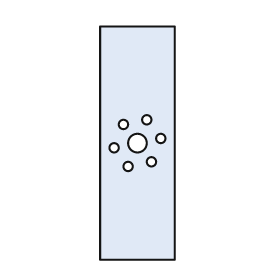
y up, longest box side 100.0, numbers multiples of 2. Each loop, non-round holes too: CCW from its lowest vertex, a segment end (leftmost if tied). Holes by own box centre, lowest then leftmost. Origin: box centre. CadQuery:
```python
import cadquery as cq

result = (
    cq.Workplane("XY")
    .moveTo(-16.0, -50.0)
    .lineTo(16.0, -50.0)
    .lineTo(16.0, 50.0)
    .lineTo(-16.0, 50.0)
    .close()
    .moveTo(-4.0, -10.0)
    .circle(2.0)
    .moveTo(6.0, -8.0)
    .circle(2.0)
    .moveTo(-10.0, -2.0)
    .circle(2.0)
    .moveTo(0.0, 0.0)
    .circle(4.0)
    .moveTo(10.0, 2.0)
    .circle(2.0)
    .moveTo(-6.0, 8.0)
    .circle(2.0)
    .moveTo(4.0, 10.0)
    .circle(2.0)
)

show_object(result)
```